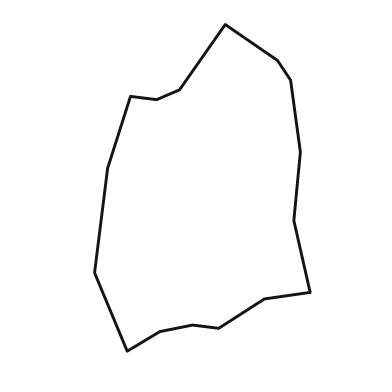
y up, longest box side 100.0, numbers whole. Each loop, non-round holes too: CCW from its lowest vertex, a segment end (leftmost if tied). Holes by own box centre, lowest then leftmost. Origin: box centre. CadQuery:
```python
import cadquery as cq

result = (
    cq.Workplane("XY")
    .moveTo(-23.0, -50.0)
    .lineTo(-13.0, -44.0)
    .lineTo(-3.0, -42.0)
    .lineTo(5.0, -43.0)
    .lineTo(19.0, -34.0)
    .lineTo(33.0, -32.0)
    .lineTo(28.0, -10.0)
    .lineTo(30.0, 11.0)
    .lineTo(27.0, 33.0)
    .lineTo(23.0, 39.0)
    .lineTo(7.0, 50.0)
    .lineTo(-7.0, 30.0)
    .lineTo(-14.0, 27.0)
    .lineTo(-22.0, 28.0)
    .lineTo(-29.0, 6.0)
    .lineTo(-33.0, -26.0)
    .close()
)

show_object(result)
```